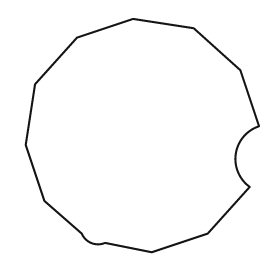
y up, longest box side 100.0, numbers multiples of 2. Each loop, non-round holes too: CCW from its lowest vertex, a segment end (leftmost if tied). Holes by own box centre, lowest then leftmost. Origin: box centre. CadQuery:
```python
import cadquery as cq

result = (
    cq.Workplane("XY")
    .moveTo(4.0, -50.0)
    .lineTo(28.0, -42.0)
    .lineTo(46.0, -22.0)
    .threePointArc((40.0, -8.0), (50.0, 4.0))
    .lineTo(42.0, 28.0)
    .lineTo(22.0, 46.0)
    .lineTo(-4.0, 50.0)
    .lineTo(-28.0, 42.0)
    .lineTo(-46.0, 22.0)
    .lineTo(-50.0, -4.0)
    .lineTo(-42.0, -28.0)
    .lineTo(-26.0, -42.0)
    .threePointArc((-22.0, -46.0), (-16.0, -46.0))
    .close()
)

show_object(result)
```